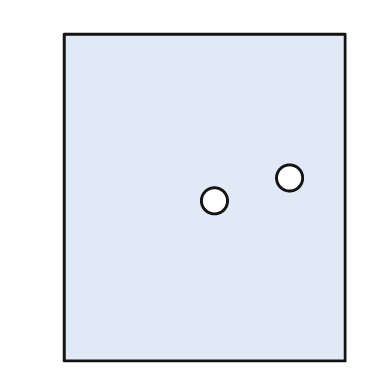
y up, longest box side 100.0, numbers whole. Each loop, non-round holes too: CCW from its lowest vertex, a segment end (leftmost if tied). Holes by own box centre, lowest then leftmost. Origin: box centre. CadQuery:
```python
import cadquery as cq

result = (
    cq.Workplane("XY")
    .moveTo(-43.0, -50.0)
    .lineTo(43.0, -50.0)
    .lineTo(43.0, 50.0)
    .lineTo(-43.0, 50.0)
    .close()
    .moveTo(3.0, -1.0)
    .circle(4.0)
    .moveTo(26.0, 6.0)
    .circle(4.0)
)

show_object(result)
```